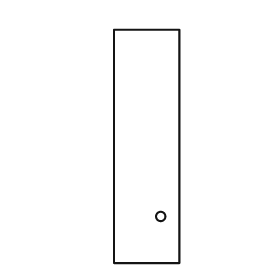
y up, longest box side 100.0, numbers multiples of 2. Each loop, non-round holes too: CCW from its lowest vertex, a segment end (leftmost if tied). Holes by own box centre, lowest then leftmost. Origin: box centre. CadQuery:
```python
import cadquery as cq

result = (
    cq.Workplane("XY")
    .moveTo(-14.0, -50.0)
    .lineTo(14.0, -50.0)
    .lineTo(14.0, 50.0)
    .lineTo(-14.0, 50.0)
    .close()
    .moveTo(6.0, -30.0)
    .circle(2.0)
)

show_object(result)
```